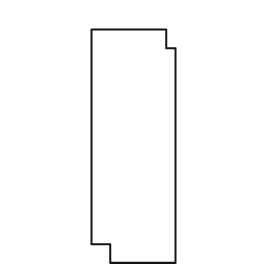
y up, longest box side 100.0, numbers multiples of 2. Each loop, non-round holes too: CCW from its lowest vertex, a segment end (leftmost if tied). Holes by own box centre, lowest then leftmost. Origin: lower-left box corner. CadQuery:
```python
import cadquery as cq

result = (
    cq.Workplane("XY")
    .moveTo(8.0, 0.0)
    .lineTo(36.0, 0.0)
    .lineTo(36.0, 92.0)
    .lineTo(32.0, 92.0)
    .lineTo(32.0, 100.0)
    .lineTo(0.0, 100.0)
    .lineTo(0.0, 8.0)
    .lineTo(8.0, 8.0)
    .close()
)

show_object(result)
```